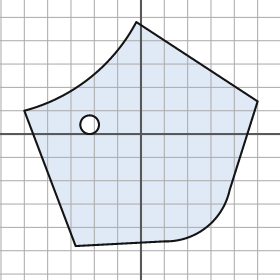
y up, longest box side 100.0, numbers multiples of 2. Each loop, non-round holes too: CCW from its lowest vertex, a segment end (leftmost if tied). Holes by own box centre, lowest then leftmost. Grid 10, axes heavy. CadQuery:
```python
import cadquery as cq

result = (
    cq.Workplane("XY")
    .moveTo(-28.0, -48.0)
    .lineTo(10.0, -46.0)
    .threePointArc((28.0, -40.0), (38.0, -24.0))
    .lineTo(50.0, 14.0)
    .lineTo(-2.0, 48.0)
    .threePointArc((-22.0, 24.0), (-50.0, 10.0))
    .close()
    .moveTo(-22.0, 4.0)
    .circle(4.0)
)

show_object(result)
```